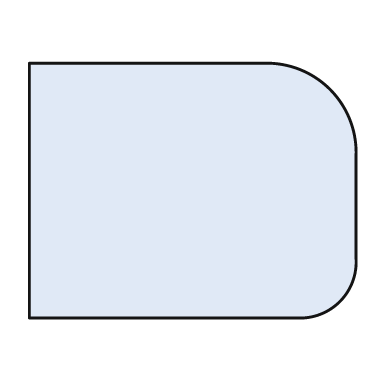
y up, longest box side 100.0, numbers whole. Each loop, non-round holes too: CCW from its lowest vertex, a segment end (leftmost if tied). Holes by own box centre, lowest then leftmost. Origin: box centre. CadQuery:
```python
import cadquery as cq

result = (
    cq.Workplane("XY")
    .moveTo(-50.0, -39.0)
    .lineTo(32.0, -39.0)
    .threePointArc((45.0, -34.0), (50.0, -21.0))
    .lineTo(50.0, 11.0)
    .threePointArc((42.0, 31.0), (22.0, 39.0))
    .lineTo(-50.0, 39.0)
    .close()
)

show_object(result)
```